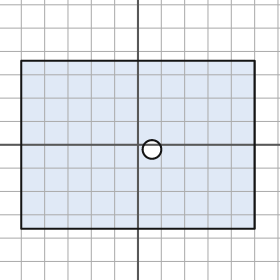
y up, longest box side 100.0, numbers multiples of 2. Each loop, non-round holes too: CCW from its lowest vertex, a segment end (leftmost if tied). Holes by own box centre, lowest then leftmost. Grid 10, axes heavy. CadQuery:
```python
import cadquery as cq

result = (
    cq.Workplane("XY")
    .moveTo(-50.0, -36.0)
    .lineTo(50.0, -36.0)
    .lineTo(50.0, 36.0)
    .lineTo(-50.0, 36.0)
    .close()
    .moveTo(6.0, -2.0)
    .circle(4.0)
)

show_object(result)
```